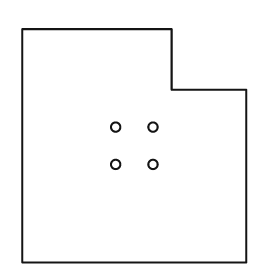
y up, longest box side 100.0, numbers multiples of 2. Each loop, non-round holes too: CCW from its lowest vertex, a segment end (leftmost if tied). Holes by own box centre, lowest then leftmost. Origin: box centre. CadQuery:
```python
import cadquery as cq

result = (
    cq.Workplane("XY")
    .moveTo(-48.0, -50.0)
    .lineTo(48.0, -50.0)
    .lineTo(48.0, 24.0)
    .lineTo(16.0, 24.0)
    .lineTo(16.0, 50.0)
    .lineTo(-48.0, 50.0)
    .close()
    .moveTo(-8.0, -8.0)
    .circle(2.0)
    .moveTo(8.0, -8.0)
    .circle(2.0)
    .moveTo(-8.0, 8.0)
    .circle(2.0)
    .moveTo(8.0, 8.0)
    .circle(2.0)
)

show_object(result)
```